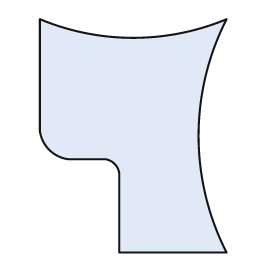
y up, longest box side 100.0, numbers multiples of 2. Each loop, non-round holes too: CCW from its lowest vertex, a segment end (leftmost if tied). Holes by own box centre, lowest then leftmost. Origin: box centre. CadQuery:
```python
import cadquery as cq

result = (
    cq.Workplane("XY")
    .moveTo(-6.0, -50.0)
    .lineTo(40.0, -50.0)
    .threePointArc((28.0, 0.0), (40.0, 50.0))
    .threePointArc((0.0, 42.0), (-40.0, 50.0))
    .lineTo(-40.0, 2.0)
    .threePointArc((-36.0, -6.0), (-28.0, -10.0))
    .lineTo(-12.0, -10.0)
    .threePointArc((-8.0, -12.0), (-6.0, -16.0))
    .close()
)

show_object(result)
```